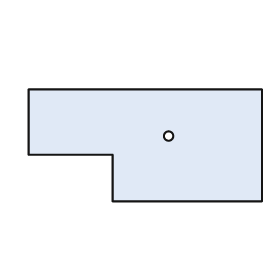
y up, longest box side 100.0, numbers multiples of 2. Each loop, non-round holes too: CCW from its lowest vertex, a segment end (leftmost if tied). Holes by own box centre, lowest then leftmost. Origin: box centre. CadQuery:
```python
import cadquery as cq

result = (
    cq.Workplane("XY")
    .moveTo(-14.0, -24.0)
    .lineTo(50.0, -24.0)
    .lineTo(50.0, 24.0)
    .lineTo(-50.0, 24.0)
    .lineTo(-50.0, -4.0)
    .lineTo(-14.0, -4.0)
    .close()
    .moveTo(10.0, 4.0)
    .circle(2.0)
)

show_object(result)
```